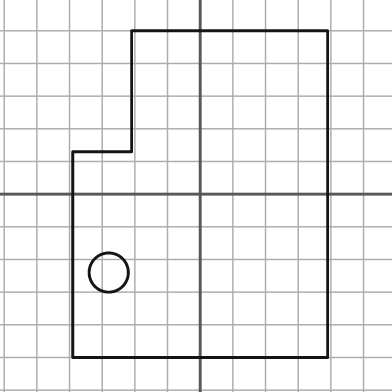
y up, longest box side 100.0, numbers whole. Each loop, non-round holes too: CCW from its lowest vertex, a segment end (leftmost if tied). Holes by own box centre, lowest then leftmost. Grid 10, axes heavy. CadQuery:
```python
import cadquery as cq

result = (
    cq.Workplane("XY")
    .moveTo(-39.0, -50.0)
    .lineTo(39.0, -50.0)
    .lineTo(39.0, 50.0)
    .lineTo(-21.0, 50.0)
    .lineTo(-21.0, 13.0)
    .lineTo(-39.0, 13.0)
    .close()
    .moveTo(-28.0, -24.0)
    .circle(6.0)
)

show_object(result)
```